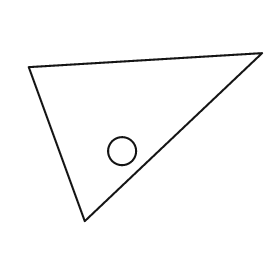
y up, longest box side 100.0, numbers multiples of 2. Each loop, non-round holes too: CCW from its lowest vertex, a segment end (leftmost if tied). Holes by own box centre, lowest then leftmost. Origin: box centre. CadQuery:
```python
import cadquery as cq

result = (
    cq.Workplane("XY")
    .moveTo(-26.0, -36.0)
    .lineTo(50.0, 36.0)
    .lineTo(-50.0, 30.0)
    .close()
    .moveTo(-10.0, -6.0)
    .circle(6.0)
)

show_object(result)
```